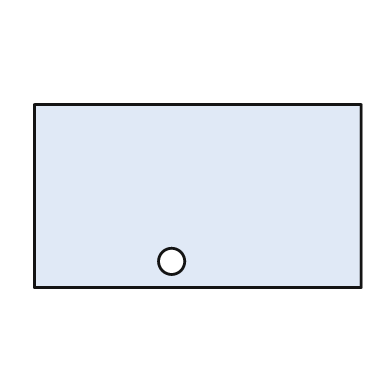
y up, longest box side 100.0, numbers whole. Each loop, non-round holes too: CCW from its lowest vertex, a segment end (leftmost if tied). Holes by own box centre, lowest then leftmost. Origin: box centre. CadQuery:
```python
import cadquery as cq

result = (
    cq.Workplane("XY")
    .moveTo(-50.0, -28.0)
    .lineTo(50.0, -28.0)
    .lineTo(50.0, 28.0)
    .lineTo(-50.0, 28.0)
    .close()
    .moveTo(-8.0, -20.0)
    .circle(4.0)
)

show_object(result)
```